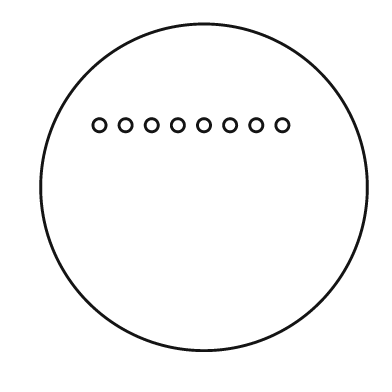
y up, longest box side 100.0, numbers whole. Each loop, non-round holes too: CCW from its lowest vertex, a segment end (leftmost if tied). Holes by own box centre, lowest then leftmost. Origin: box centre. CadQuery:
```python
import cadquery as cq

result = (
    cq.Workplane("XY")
    .moveTo(0.0, 0.0)
    .circle(50.0)
    .moveTo(-32.0, 19.0)
    .circle(2.0)
    .moveTo(-24.0, 19.0)
    .circle(2.0)
    .moveTo(-16.0, 19.0)
    .circle(2.0)
    .moveTo(-8.0, 19.0)
    .circle(2.0)
    .moveTo(0.0, 19.0)
    .circle(2.0)
    .moveTo(8.0, 19.0)
    .circle(2.0)
    .moveTo(16.0, 19.0)
    .circle(2.0)
    .moveTo(24.0, 19.0)
    .circle(2.0)
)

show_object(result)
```